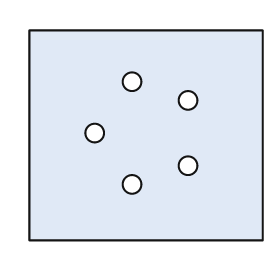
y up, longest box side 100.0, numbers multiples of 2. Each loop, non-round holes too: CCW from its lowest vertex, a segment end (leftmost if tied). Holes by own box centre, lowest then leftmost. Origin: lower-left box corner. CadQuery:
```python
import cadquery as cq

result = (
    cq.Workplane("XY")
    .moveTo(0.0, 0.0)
    .lineTo(100.0, 0.0)
    .lineTo(100.0, 90.0)
    .lineTo(0.0, 90.0)
    .close()
    .moveTo(44.0, 24.0)
    .circle(4.0)
    .moveTo(68.0, 32.0)
    .circle(4.0)
    .moveTo(28.0, 46.0)
    .circle(4.0)
    .moveTo(68.0, 60.0)
    .circle(4.0)
    .moveTo(44.0, 68.0)
    .circle(4.0)
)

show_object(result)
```